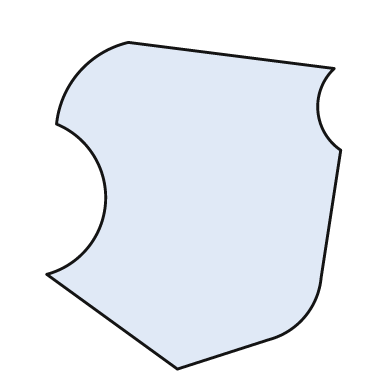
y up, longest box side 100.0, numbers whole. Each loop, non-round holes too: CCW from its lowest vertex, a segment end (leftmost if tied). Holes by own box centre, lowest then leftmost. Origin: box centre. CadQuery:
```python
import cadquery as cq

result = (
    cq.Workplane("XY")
    .moveTo(-5.0, -50.0)
    .lineTo(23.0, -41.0)
    .threePointArc((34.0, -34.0), (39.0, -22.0))
    .lineTo(45.0, 17.0)
    .threePointArc((38.0, 29.0), (43.0, 42.0))
    .lineTo(-20.0, 50.0)
    .threePointArc((-35.0, 41.0), (-42.0, 25.0))
    .threePointArc((-27.0, 1.0), (-45.0, -21.0))
    .close()
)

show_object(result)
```